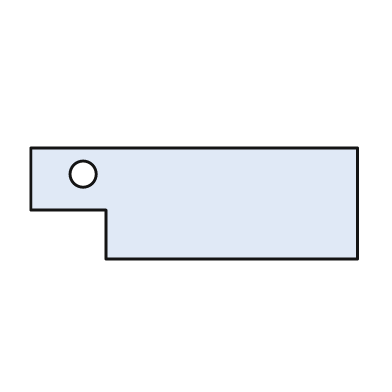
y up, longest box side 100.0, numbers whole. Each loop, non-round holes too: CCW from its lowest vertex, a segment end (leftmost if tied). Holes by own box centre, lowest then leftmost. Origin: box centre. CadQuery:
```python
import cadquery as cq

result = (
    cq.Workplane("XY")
    .moveTo(-27.0, -17.0)
    .lineTo(50.0, -17.0)
    .lineTo(50.0, 17.0)
    .lineTo(-50.0, 17.0)
    .lineTo(-50.0, -2.0)
    .lineTo(-27.0, -2.0)
    .close()
    .moveTo(-34.0, 9.0)
    .circle(4.0)
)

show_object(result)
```